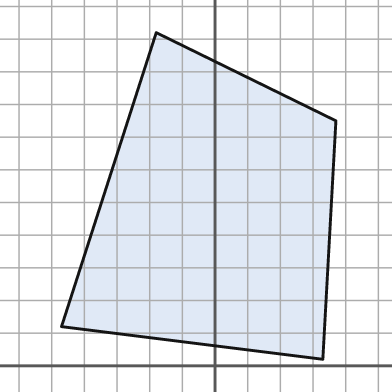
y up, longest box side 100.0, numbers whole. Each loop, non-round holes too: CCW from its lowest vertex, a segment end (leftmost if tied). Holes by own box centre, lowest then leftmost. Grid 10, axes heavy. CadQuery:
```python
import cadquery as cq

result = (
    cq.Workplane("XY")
    .moveTo(33.0, 2.0)
    .lineTo(37.0, 75.0)
    .lineTo(-18.0, 102.0)
    .lineTo(-47.0, 12.0)
    .close()
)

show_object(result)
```